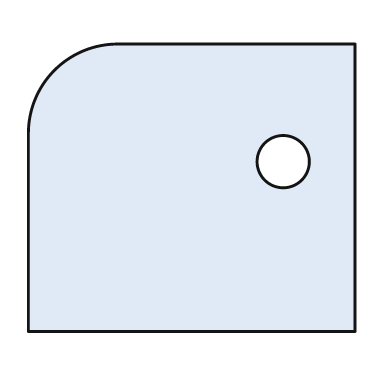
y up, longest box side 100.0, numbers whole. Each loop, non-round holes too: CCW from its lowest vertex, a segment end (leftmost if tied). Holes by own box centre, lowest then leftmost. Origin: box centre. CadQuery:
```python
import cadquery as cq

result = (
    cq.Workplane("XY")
    .moveTo(-50.0, -44.0)
    .lineTo(50.0, -44.0)
    .lineTo(50.0, 44.0)
    .lineTo(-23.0, 44.0)
    .threePointArc((-42.0, 36.0), (-50.0, 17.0))
    .close()
    .moveTo(28.0, 8.0)
    .circle(8.0)
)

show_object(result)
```